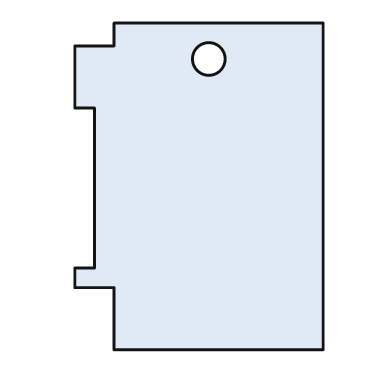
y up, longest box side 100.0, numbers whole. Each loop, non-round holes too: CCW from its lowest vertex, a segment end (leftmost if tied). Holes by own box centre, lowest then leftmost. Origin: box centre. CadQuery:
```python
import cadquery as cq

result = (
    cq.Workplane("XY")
    .moveTo(-26.0, -50.0)
    .lineTo(38.0, -50.0)
    .lineTo(38.0, 50.0)
    .lineTo(-26.0, 50.0)
    .lineTo(-26.0, 43.0)
    .lineTo(-38.0, 43.0)
    .lineTo(-38.0, 24.0)
    .lineTo(-32.0, 24.0)
    .lineTo(-32.0, -25.0)
    .lineTo(-38.0, -25.0)
    .lineTo(-38.0, -31.0)
    .lineTo(-26.0, -31.0)
    .close()
    .moveTo(3.0, 39.0)
    .circle(5.0)
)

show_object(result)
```